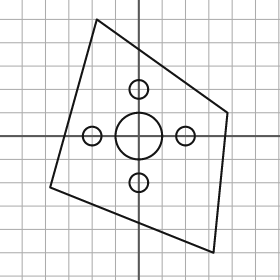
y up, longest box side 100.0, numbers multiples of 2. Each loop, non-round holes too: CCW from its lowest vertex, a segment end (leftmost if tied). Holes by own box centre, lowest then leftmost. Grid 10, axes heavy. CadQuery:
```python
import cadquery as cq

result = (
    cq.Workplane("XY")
    .moveTo(32.0, -50.0)
    .lineTo(38.0, 10.0)
    .lineTo(-18.0, 50.0)
    .lineTo(-38.0, -22.0)
    .close()
    .moveTo(0.0, -20.0)
    .circle(4.0)
    .moveTo(-20.0, 0.0)
    .circle(4.0)
    .moveTo(0.0, 0.0)
    .circle(10.0)
    .moveTo(20.0, 0.0)
    .circle(4.0)
    .moveTo(0.0, 20.0)
    .circle(4.0)
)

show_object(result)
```